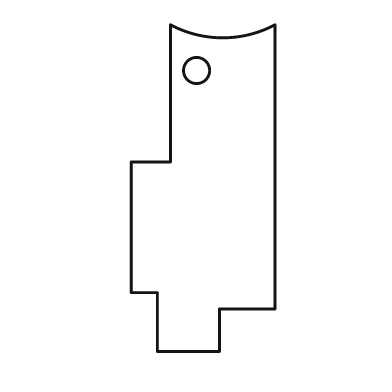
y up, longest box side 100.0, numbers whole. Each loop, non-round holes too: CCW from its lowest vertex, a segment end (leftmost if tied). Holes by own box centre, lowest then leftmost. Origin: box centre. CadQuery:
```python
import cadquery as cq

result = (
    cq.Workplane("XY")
    .moveTo(-14.0, -50.0)
    .lineTo(5.0, -50.0)
    .lineTo(5.0, -37.0)
    .lineTo(22.0, -37.0)
    .lineTo(22.0, 50.0)
    .threePointArc((6.0, 46.0), (-10.0, 50.0))
    .lineTo(-10.0, 8.0)
    .lineTo(-22.0, 8.0)
    .lineTo(-22.0, -32.0)
    .lineTo(-14.0, -32.0)
    .close()
    .moveTo(-2.0, 36.0)
    .circle(4.0)
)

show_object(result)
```